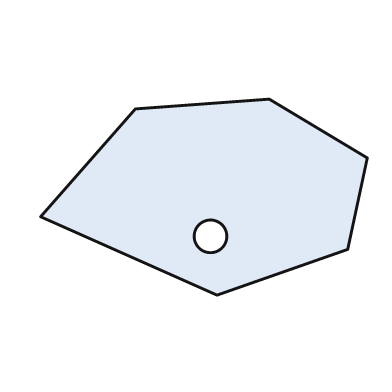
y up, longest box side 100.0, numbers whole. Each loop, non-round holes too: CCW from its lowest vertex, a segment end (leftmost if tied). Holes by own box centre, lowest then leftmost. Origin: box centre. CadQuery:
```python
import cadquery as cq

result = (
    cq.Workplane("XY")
    .moveTo(4.0, -30.0)
    .lineTo(44.0, -16.0)
    .lineTo(50.0, 12.0)
    .lineTo(20.0, 30.0)
    .lineTo(-21.0, 27.0)
    .lineTo(-50.0, -6.0)
    .close()
    .moveTo(2.0, -12.0)
    .circle(5.0)
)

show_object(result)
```